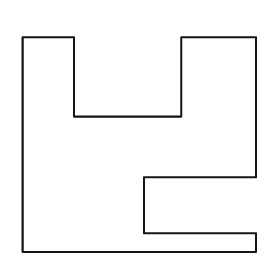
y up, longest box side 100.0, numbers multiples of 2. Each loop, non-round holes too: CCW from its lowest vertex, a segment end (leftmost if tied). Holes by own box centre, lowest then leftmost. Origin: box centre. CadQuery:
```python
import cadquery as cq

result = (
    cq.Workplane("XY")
    .moveTo(-50.0, -46.0)
    .lineTo(50.0, -46.0)
    .lineTo(50.0, -38.0)
    .lineTo(2.0, -38.0)
    .lineTo(2.0, -14.0)
    .lineTo(50.0, -14.0)
    .lineTo(50.0, 46.0)
    .lineTo(18.0, 46.0)
    .lineTo(18.0, 12.0)
    .lineTo(-28.0, 12.0)
    .lineTo(-28.0, 46.0)
    .lineTo(-50.0, 46.0)
    .close()
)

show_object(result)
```